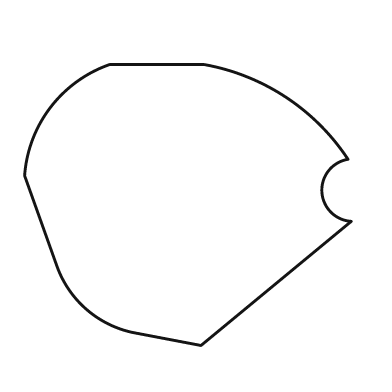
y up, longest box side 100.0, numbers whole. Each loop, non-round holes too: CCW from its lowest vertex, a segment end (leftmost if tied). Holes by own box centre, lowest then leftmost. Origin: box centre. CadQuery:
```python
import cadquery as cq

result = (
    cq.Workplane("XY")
    .moveTo(4.0, -43.0)
    .lineTo(50.0, -5.0)
    .threePointArc((41.0, 4.0), (49.0, 14.0))
    .threePointArc((30.0, 33.0), (5.0, 43.0))
    .lineTo(-24.0, 43.0)
    .threePointArc((-42.0, 30.0), (-50.0, 9.0))
    .lineTo(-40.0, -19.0)
    .threePointArc((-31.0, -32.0), (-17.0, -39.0))
    .close()
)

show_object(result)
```